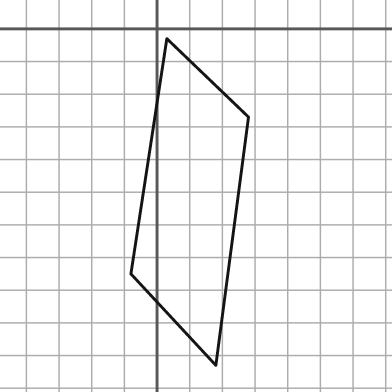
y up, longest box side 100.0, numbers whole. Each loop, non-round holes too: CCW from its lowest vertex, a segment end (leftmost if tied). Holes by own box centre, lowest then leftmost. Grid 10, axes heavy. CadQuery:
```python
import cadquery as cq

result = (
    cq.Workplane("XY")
    .moveTo(18.0, -103.0)
    .lineTo(28.0, -27.0)
    .lineTo(3.0, -3.0)
    .lineTo(-8.0, -75.0)
    .close()
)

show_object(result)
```